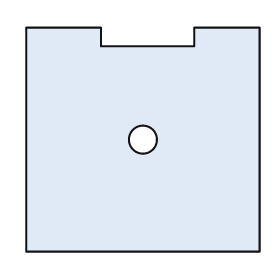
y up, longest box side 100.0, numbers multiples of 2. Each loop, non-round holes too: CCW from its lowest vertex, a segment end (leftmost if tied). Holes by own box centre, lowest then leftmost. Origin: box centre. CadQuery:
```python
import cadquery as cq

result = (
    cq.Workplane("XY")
    .moveTo(-50.0, -48.0)
    .lineTo(50.0, -48.0)
    .lineTo(50.0, 48.0)
    .lineTo(22.0, 48.0)
    .lineTo(22.0, 40.0)
    .lineTo(-18.0, 40.0)
    .lineTo(-18.0, 48.0)
    .lineTo(-50.0, 48.0)
    .close()
    .moveTo(0.0, 0.0)
    .circle(6.0)
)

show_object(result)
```